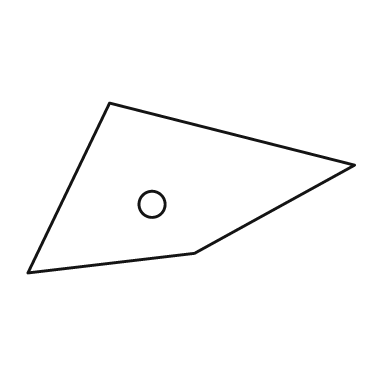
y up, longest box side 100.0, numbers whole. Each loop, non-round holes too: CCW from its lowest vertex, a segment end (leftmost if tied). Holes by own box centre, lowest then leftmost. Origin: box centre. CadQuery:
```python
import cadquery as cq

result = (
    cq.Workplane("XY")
    .moveTo(-50.0, -26.0)
    .lineTo(1.0, -20.0)
    .lineTo(50.0, 7.0)
    .lineTo(-25.0, 26.0)
    .close()
    .moveTo(-12.0, -5.0)
    .circle(4.0)
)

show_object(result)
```